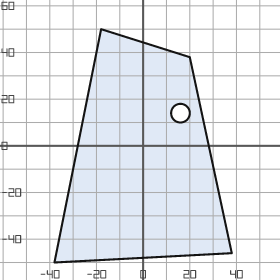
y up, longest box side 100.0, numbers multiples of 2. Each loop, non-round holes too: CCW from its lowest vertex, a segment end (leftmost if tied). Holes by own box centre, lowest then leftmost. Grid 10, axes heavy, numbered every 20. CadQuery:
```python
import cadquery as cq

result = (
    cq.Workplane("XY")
    .moveTo(-38.0, -50.0)
    .lineTo(38.0, -46.0)
    .lineTo(20.0, 38.0)
    .lineTo(-18.0, 50.0)
    .close()
    .moveTo(16.0, 14.0)
    .circle(4.0)
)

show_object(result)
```